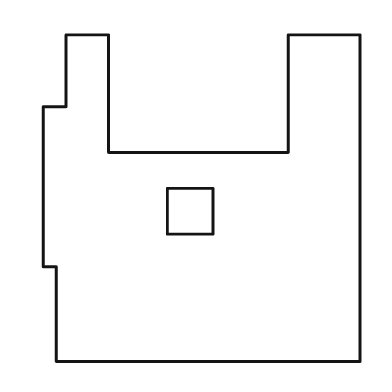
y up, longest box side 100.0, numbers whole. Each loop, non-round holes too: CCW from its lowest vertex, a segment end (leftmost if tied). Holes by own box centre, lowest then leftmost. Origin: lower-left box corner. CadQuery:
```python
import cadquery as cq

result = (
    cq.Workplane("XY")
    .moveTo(4.0, 0.0)
    .lineTo(97.0, 0.0)
    .lineTo(97.0, 100.0)
    .lineTo(75.0, 100.0)
    .lineTo(75.0, 64.0)
    .lineTo(20.0, 64.0)
    .lineTo(20.0, 100.0)
    .lineTo(7.0, 100.0)
    .lineTo(7.0, 78.0)
    .lineTo(0.0, 78.0)
    .lineTo(0.0, 29.0)
    .lineTo(4.0, 29.0)
    .close()
    .moveTo(38.0, 39.0)
    .lineTo(52.0, 39.0)
    .lineTo(52.0, 53.0)
    .lineTo(38.0, 53.0)
    .close()
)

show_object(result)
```